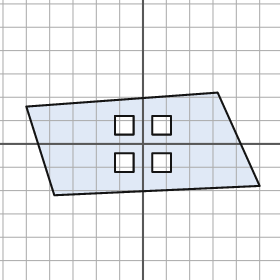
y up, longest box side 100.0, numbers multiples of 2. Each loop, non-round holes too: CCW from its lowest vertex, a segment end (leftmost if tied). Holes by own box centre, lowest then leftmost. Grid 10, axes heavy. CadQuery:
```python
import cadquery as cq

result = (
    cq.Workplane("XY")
    .moveTo(-38.0, -22.0)
    .lineTo(50.0, -18.0)
    .lineTo(32.0, 22.0)
    .lineTo(-50.0, 16.0)
    .close()
    .moveTo(-12.0, -12.0)
    .lineTo(-4.0, -12.0)
    .lineTo(-4.0, -4.0)
    .lineTo(-12.0, -4.0)
    .close()
    .moveTo(4.0, -12.0)
    .lineTo(12.0, -12.0)
    .lineTo(12.0, -4.0)
    .lineTo(4.0, -4.0)
    .close()
    .moveTo(-12.0, 4.0)
    .lineTo(-4.0, 4.0)
    .lineTo(-4.0, 12.0)
    .lineTo(-12.0, 12.0)
    .close()
    .moveTo(4.0, 4.0)
    .lineTo(12.0, 4.0)
    .lineTo(12.0, 12.0)
    .lineTo(4.0, 12.0)
    .close()
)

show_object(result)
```